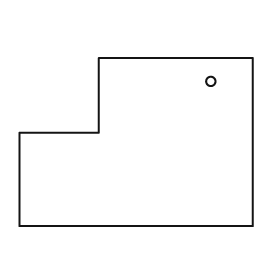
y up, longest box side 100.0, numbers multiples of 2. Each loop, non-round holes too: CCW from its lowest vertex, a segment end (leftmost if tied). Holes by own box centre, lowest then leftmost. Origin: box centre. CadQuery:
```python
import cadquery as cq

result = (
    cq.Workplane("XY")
    .moveTo(-50.0, -36.0)
    .lineTo(50.0, -36.0)
    .lineTo(50.0, 36.0)
    .lineTo(-16.0, 36.0)
    .lineTo(-16.0, 4.0)
    .lineTo(-50.0, 4.0)
    .close()
    .moveTo(32.0, 26.0)
    .circle(2.0)
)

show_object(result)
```